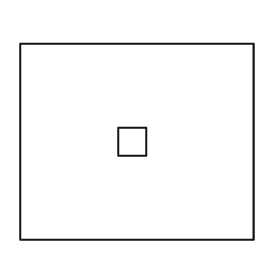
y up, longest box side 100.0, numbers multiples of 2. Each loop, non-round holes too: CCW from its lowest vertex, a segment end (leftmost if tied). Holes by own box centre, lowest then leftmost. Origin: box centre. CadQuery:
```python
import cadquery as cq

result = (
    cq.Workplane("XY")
    .moveTo(-50.0, -42.0)
    .lineTo(50.0, -42.0)
    .lineTo(50.0, 42.0)
    .lineTo(-50.0, 42.0)
    .close()
    .moveTo(-8.0, -6.0)
    .lineTo(4.0, -6.0)
    .lineTo(4.0, 6.0)
    .lineTo(-8.0, 6.0)
    .close()
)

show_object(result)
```